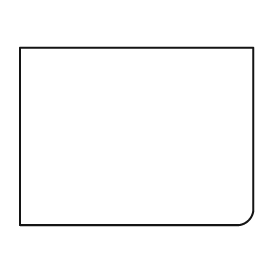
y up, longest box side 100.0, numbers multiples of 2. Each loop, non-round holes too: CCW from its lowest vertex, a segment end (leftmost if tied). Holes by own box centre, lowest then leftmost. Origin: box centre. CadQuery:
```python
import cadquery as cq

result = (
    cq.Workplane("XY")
    .moveTo(-50.0, -38.0)
    .lineTo(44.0, -38.0)
    .threePointArc((48.0, -36.0), (50.0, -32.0))
    .lineTo(50.0, 38.0)
    .lineTo(-50.0, 38.0)
    .close()
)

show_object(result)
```